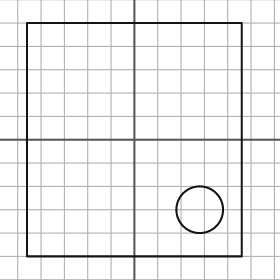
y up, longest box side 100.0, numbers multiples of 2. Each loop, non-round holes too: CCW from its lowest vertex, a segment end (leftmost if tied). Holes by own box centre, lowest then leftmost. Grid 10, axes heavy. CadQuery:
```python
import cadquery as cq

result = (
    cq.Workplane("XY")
    .moveTo(-46.0, -50.0)
    .lineTo(46.0, -50.0)
    .lineTo(46.0, 50.0)
    .lineTo(-46.0, 50.0)
    .close()
    .moveTo(28.0, -30.0)
    .circle(10.0)
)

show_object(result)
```